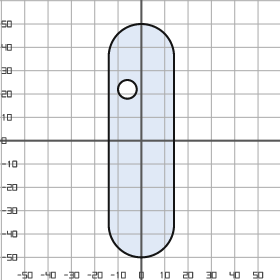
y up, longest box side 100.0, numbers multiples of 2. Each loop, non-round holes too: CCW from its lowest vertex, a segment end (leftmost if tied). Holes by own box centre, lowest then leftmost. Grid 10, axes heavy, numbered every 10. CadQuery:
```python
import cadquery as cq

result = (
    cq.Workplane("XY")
    .moveTo(-14.0, -36.0)
    .threePointArc((0.0, -50.0), (14.0, -36.0))
    .lineTo(14.0, 36.0)
    .threePointArc((0.0, 50.0), (-14.0, 36.0))
    .close()
    .moveTo(-6.0, 22.0)
    .circle(4.0)
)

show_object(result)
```